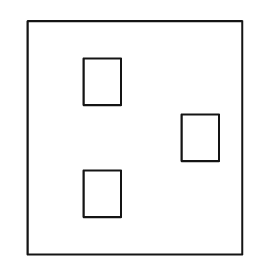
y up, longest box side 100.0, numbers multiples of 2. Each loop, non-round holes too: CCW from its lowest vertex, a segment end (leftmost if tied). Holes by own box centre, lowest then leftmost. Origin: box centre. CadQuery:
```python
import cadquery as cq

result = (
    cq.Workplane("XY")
    .moveTo(-46.0, -50.0)
    .lineTo(46.0, -50.0)
    .lineTo(46.0, 50.0)
    .lineTo(-46.0, 50.0)
    .close()
    .moveTo(-22.0, -34.0)
    .lineTo(-6.0, -34.0)
    .lineTo(-6.0, -14.0)
    .lineTo(-22.0, -14.0)
    .close()
    .moveTo(20.0, -10.0)
    .lineTo(36.0, -10.0)
    .lineTo(36.0, 10.0)
    .lineTo(20.0, 10.0)
    .close()
    .moveTo(-22.0, 14.0)
    .lineTo(-6.0, 14.0)
    .lineTo(-6.0, 34.0)
    .lineTo(-22.0, 34.0)
    .close()
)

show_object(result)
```